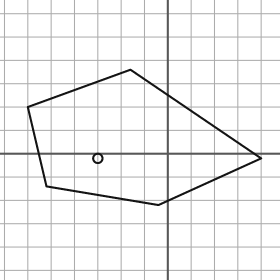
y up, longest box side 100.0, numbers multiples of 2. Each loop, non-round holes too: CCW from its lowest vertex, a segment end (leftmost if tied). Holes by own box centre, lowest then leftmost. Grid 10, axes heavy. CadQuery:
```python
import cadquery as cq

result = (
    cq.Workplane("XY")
    .moveTo(-4.0, -22.0)
    .lineTo(40.0, -2.0)
    .lineTo(-16.0, 36.0)
    .lineTo(-60.0, 20.0)
    .lineTo(-52.0, -14.0)
    .close()
    .moveTo(-30.0, -2.0)
    .circle(2.0)
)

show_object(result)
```